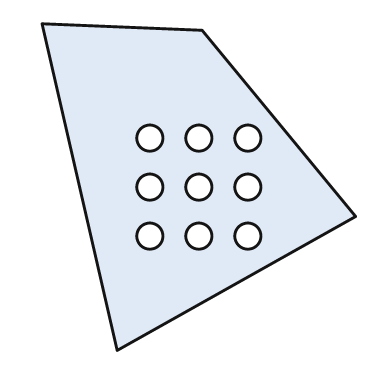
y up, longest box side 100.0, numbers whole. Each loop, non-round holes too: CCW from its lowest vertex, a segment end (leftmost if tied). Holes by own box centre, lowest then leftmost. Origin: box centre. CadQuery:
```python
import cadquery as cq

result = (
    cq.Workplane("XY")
    .moveTo(-25.0, -50.0)
    .lineTo(48.0, -9.0)
    .lineTo(1.0, 48.0)
    .lineTo(-48.0, 50.0)
    .close()
    .moveTo(-15.0, -15.0)
    .circle(4.0)
    .moveTo(0.0, -15.0)
    .circle(4.0)
    .moveTo(15.0, -15.0)
    .circle(4.0)
    .moveTo(-15.0, 0.0)
    .circle(4.0)
    .moveTo(0.0, 0.0)
    .circle(4.0)
    .moveTo(15.0, 0.0)
    .circle(4.0)
    .moveTo(-15.0, 15.0)
    .circle(4.0)
    .moveTo(0.0, 15.0)
    .circle(4.0)
    .moveTo(15.0, 15.0)
    .circle(4.0)
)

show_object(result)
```